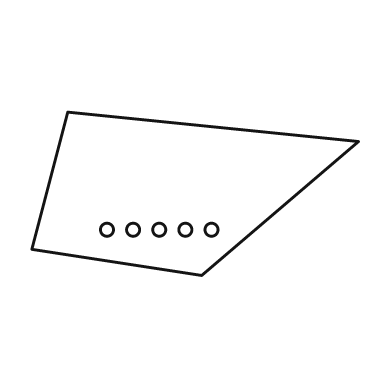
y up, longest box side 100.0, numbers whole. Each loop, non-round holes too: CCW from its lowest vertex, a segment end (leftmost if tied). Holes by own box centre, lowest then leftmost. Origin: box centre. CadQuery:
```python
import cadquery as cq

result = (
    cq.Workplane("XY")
    .moveTo(2.0, -25.0)
    .lineTo(50.0, 16.0)
    .lineTo(-39.0, 25.0)
    .lineTo(-50.0, -17.0)
    .close()
    .moveTo(-27.0, -11.0)
    .circle(2.0)
    .moveTo(-19.0, -11.0)
    .circle(2.0)
    .moveTo(-11.0, -11.0)
    .circle(2.0)
    .moveTo(-3.0, -11.0)
    .circle(2.0)
    .moveTo(5.0, -11.0)
    .circle(2.0)
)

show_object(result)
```